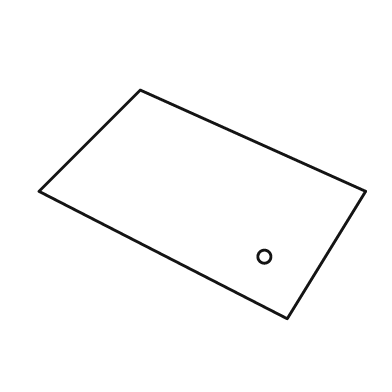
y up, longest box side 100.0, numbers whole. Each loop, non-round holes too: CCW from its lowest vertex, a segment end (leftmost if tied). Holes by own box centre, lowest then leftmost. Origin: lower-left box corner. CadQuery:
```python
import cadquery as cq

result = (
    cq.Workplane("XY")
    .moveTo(76.0, 0.0)
    .lineTo(100.0, 39.0)
    .lineTo(31.0, 70.0)
    .lineTo(0.0, 39.0)
    .close()
    .moveTo(69.0, 19.0)
    .circle(2.0)
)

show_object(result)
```